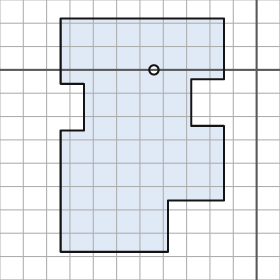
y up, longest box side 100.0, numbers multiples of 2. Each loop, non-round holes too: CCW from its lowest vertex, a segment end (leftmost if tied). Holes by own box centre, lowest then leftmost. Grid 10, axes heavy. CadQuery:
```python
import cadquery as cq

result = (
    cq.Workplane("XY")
    .moveTo(-84.0, -78.0)
    .lineTo(-38.0, -78.0)
    .lineTo(-38.0, -56.0)
    .lineTo(-14.0, -56.0)
    .lineTo(-14.0, -24.0)
    .lineTo(-28.0, -24.0)
    .lineTo(-28.0, -4.0)
    .lineTo(-14.0, -4.0)
    .lineTo(-14.0, 22.0)
    .lineTo(-84.0, 22.0)
    .lineTo(-84.0, -6.0)
    .lineTo(-74.0, -6.0)
    .lineTo(-74.0, -26.0)
    .lineTo(-84.0, -26.0)
    .close()
    .moveTo(-44.0, 0.0)
    .circle(2.0)
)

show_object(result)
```